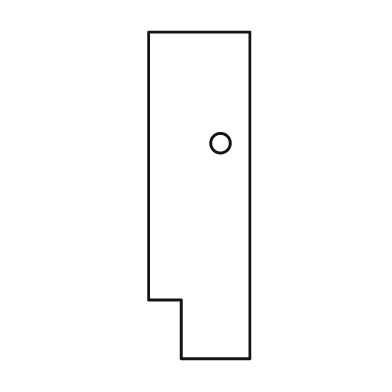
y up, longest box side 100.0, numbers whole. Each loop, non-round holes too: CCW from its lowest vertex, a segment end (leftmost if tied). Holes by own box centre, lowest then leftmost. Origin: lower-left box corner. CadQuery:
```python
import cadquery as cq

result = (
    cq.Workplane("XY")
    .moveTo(10.0, 0.0)
    .lineTo(31.0, 0.0)
    .lineTo(31.0, 100.0)
    .lineTo(0.0, 100.0)
    .lineTo(0.0, 18.0)
    .lineTo(10.0, 18.0)
    .close()
    .moveTo(22.0, 66.0)
    .circle(3.0)
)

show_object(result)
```